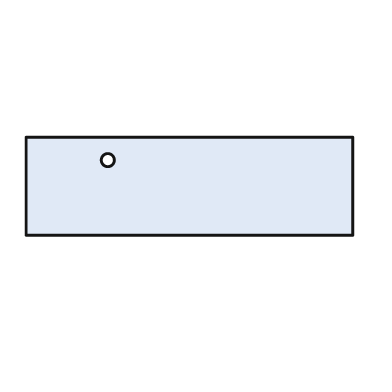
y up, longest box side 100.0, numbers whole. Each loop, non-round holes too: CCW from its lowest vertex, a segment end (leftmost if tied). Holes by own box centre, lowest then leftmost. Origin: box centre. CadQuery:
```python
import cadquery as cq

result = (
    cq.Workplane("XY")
    .moveTo(-50.0, -15.0)
    .lineTo(50.0, -15.0)
    .lineTo(50.0, 15.0)
    .lineTo(-50.0, 15.0)
    .close()
    .moveTo(-25.0, 8.0)
    .circle(2.0)
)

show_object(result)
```